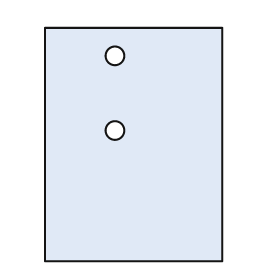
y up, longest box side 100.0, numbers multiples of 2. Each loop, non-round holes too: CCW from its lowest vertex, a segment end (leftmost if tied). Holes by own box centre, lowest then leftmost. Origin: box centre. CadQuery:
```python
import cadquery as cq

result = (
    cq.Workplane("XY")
    .moveTo(-38.0, -50.0)
    .lineTo(38.0, -50.0)
    .lineTo(38.0, 50.0)
    .lineTo(-38.0, 50.0)
    .close()
    .moveTo(-8.0, 6.0)
    .circle(4.0)
    .moveTo(-8.0, 38.0)
    .circle(4.0)
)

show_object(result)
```